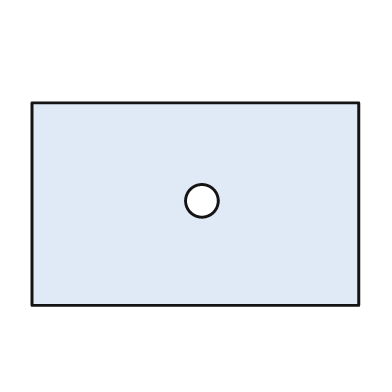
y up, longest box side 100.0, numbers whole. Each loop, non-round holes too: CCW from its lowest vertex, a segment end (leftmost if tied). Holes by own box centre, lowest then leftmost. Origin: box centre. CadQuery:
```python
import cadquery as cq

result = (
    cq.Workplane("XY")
    .moveTo(-50.0, -31.0)
    .lineTo(50.0, -31.0)
    .lineTo(50.0, 31.0)
    .lineTo(-50.0, 31.0)
    .close()
    .moveTo(2.0, 1.0)
    .circle(5.0)
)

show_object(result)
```